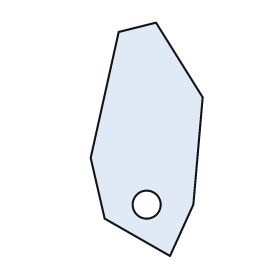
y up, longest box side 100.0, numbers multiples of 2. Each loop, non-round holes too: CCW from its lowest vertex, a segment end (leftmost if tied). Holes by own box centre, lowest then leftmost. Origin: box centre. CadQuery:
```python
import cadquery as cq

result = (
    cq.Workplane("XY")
    .moveTo(10.0, -50.0)
    .lineTo(20.0, -28.0)
    .lineTo(24.0, 18.0)
    .lineTo(4.0, 50.0)
    .lineTo(-12.0, 46.0)
    .lineTo(-24.0, -8.0)
    .lineTo(-18.0, -34.0)
    .close()
    .moveTo(0.0, -28.0)
    .circle(6.0)
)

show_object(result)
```